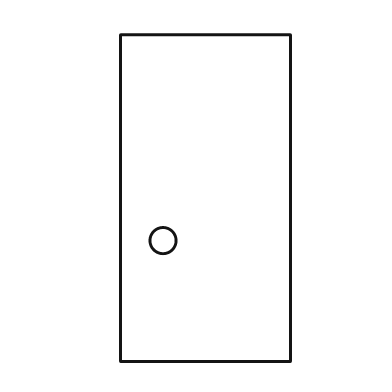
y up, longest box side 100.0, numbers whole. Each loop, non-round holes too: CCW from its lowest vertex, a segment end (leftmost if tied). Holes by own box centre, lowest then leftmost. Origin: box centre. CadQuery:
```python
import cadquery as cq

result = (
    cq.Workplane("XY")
    .moveTo(-26.0, -50.0)
    .lineTo(26.0, -50.0)
    .lineTo(26.0, 50.0)
    .lineTo(-26.0, 50.0)
    .close()
    .moveTo(-13.0, -13.0)
    .circle(4.0)
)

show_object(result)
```